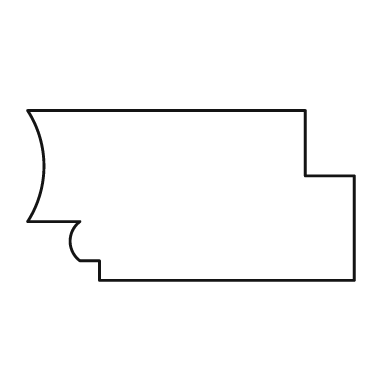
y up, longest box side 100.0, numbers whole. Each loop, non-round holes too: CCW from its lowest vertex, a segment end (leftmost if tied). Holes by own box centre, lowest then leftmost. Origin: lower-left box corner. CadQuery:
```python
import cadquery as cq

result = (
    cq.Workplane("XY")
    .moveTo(22.0, 0.0)
    .lineTo(100.0, 0.0)
    .lineTo(100.0, 32.0)
    .lineTo(85.0, 32.0)
    .lineTo(85.0, 52.0)
    .lineTo(0.0, 52.0)
    .threePointArc((5.0, 35.0), (0.0, 18.0))
    .lineTo(16.0, 18.0)
    .threePointArc((13.0, 12.0), (16.0, 6.0))
    .lineTo(22.0, 6.0)
    .close()
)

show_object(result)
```